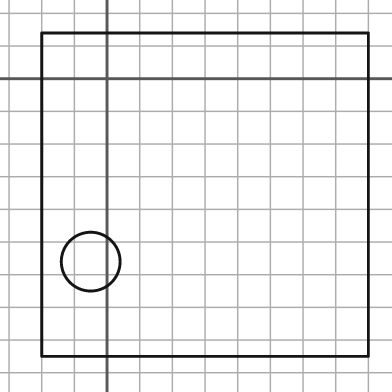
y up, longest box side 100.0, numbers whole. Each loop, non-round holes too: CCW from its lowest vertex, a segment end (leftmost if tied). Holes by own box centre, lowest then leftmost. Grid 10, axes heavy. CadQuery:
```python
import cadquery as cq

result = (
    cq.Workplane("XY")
    .moveTo(-20.0, -85.0)
    .lineTo(80.0, -85.0)
    .lineTo(80.0, 14.0)
    .lineTo(-20.0, 14.0)
    .close()
    .moveTo(-5.0, -56.0)
    .circle(9.0)
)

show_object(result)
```